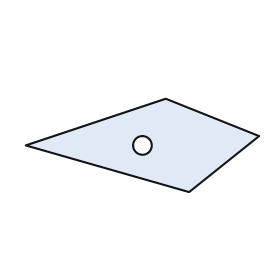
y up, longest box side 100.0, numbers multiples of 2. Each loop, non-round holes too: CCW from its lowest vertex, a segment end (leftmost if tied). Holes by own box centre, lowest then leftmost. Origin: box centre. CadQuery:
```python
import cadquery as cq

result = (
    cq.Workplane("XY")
    .moveTo(20.0, -20.0)
    .lineTo(50.0, 4.0)
    .lineTo(10.0, 20.0)
    .lineTo(-50.0, 0.0)
    .close()
    .moveTo(0.0, 0.0)
    .circle(4.0)
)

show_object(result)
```